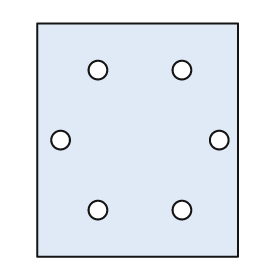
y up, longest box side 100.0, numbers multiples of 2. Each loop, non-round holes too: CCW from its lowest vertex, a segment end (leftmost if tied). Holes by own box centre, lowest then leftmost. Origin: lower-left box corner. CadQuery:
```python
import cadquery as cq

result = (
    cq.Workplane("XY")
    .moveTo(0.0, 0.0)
    .lineTo(86.0, 0.0)
    .lineTo(86.0, 100.0)
    .lineTo(0.0, 100.0)
    .close()
    .moveTo(26.0, 20.0)
    .circle(4.0)
    .moveTo(62.0, 20.0)
    .circle(4.0)
    .moveTo(10.0, 50.0)
    .circle(4.0)
    .moveTo(78.0, 50.0)
    .circle(4.0)
    .moveTo(26.0, 80.0)
    .circle(4.0)
    .moveTo(62.0, 80.0)
    .circle(4.0)
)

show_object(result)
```